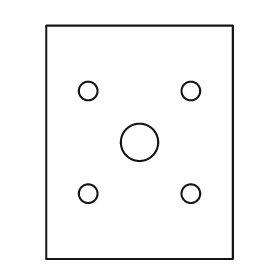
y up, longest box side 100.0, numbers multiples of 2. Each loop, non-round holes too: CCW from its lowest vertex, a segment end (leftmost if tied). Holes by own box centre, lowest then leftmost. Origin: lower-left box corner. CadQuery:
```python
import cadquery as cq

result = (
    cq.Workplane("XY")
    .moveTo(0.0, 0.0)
    .lineTo(80.0, 0.0)
    .lineTo(80.0, 100.0)
    .lineTo(0.0, 100.0)
    .close()
    .moveTo(18.0, 28.0)
    .circle(4.0)
    .moveTo(62.0, 28.0)
    .circle(4.0)
    .moveTo(40.0, 50.0)
    .circle(8.0)
    .moveTo(18.0, 72.0)
    .circle(4.0)
    .moveTo(62.0, 72.0)
    .circle(4.0)
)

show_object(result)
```